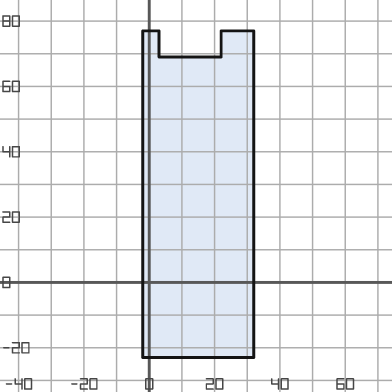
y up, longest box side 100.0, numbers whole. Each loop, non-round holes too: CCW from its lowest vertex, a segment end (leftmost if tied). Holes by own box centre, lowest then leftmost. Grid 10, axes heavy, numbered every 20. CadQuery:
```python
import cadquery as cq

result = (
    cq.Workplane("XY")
    .moveTo(-2.0, -23.0)
    .lineTo(32.0, -23.0)
    .lineTo(32.0, 77.0)
    .lineTo(22.0, 77.0)
    .lineTo(22.0, 69.0)
    .lineTo(3.0, 69.0)
    .lineTo(3.0, 77.0)
    .lineTo(-2.0, 77.0)
    .close()
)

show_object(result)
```